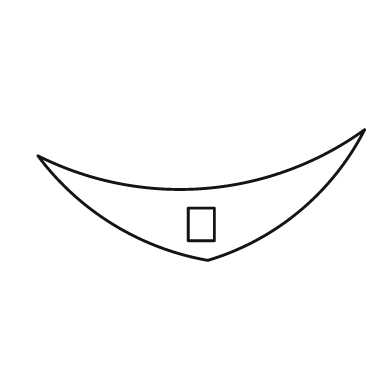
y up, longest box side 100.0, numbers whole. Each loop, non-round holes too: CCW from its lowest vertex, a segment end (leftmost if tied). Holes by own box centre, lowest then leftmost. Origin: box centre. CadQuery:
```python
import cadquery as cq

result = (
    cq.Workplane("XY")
    .moveTo(2.0, -20.0)
    .threePointArc((30.0, -5.0), (50.0, 20.0))
    .threePointArc((1.0, 2.0), (-50.0, 12.0))
    .threePointArc((-27.0, -9.0), (2.0, -20.0))
    .close()
    .moveTo(-4.0, -14.0)
    .lineTo(4.0, -14.0)
    .lineTo(4.0, -4.0)
    .lineTo(-4.0, -4.0)
    .close()
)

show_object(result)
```